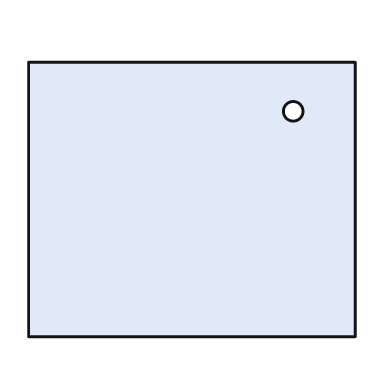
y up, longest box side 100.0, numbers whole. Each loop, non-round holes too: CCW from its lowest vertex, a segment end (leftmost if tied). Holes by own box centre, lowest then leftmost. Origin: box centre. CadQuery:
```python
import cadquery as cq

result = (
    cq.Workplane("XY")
    .moveTo(-50.0, -42.0)
    .lineTo(50.0, -42.0)
    .lineTo(50.0, 42.0)
    .lineTo(-50.0, 42.0)
    .close()
    .moveTo(31.0, 27.0)
    .circle(3.0)
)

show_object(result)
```